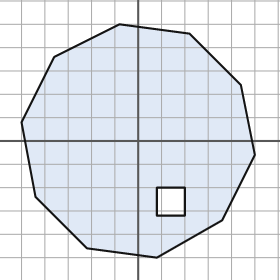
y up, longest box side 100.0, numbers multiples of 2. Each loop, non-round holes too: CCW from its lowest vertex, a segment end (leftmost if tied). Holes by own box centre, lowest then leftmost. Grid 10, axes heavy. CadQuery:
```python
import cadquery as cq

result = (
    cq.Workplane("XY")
    .moveTo(8.0, -50.0)
    .lineTo(36.0, -34.0)
    .lineTo(50.0, -6.0)
    .lineTo(44.0, 24.0)
    .lineTo(22.0, 46.0)
    .lineTo(-8.0, 50.0)
    .lineTo(-36.0, 36.0)
    .lineTo(-50.0, 8.0)
    .lineTo(-44.0, -24.0)
    .lineTo(-22.0, -46.0)
    .close()
    .moveTo(8.0, -32.0)
    .lineTo(20.0, -32.0)
    .lineTo(20.0, -20.0)
    .lineTo(8.0, -20.0)
    .close()
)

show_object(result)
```